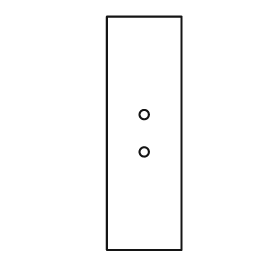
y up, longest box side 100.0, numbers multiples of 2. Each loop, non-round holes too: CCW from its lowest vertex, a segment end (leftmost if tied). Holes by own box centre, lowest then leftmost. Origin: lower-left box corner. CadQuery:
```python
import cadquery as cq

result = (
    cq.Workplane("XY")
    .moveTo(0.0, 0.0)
    .lineTo(32.0, 0.0)
    .lineTo(32.0, 100.0)
    .lineTo(0.0, 100.0)
    .close()
    .moveTo(16.0, 42.0)
    .circle(2.0)
    .moveTo(16.0, 58.0)
    .circle(2.0)
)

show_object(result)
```